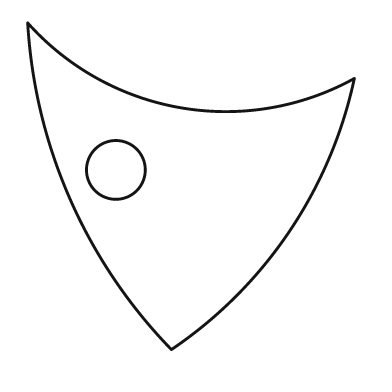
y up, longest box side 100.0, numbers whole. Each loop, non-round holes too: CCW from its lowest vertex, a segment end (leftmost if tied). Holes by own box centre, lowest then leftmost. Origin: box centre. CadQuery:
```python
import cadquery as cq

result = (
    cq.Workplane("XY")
    .moveTo(-6.0, -50.0)
    .threePointArc((30.0, -14.0), (50.0, 33.0))
    .threePointArc((-3.0, 24.0), (-50.0, 50.0))
    .threePointArc((-37.0, -4.0), (-6.0, -50.0))
    .close()
    .moveTo(-23.0, 5.0)
    .circle(9.0)
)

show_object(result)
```